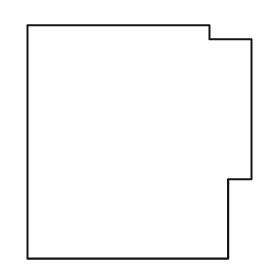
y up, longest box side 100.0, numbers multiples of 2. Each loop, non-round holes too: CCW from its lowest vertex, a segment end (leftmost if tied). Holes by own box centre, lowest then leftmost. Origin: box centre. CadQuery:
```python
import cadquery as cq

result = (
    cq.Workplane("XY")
    .moveTo(-48.0, -50.0)
    .lineTo(38.0, -50.0)
    .lineTo(38.0, -16.0)
    .lineTo(48.0, -16.0)
    .lineTo(48.0, 44.0)
    .lineTo(30.0, 44.0)
    .lineTo(30.0, 50.0)
    .lineTo(-48.0, 50.0)
    .close()
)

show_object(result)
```